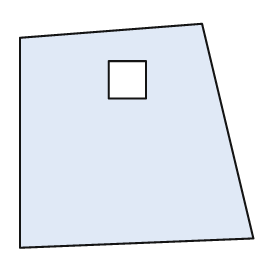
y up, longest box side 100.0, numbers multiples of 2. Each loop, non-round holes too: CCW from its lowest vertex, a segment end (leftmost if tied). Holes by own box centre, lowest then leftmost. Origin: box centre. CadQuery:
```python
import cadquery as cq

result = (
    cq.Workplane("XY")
    .moveTo(-50.0, -48.0)
    .lineTo(50.0, -44.0)
    .lineTo(28.0, 48.0)
    .lineTo(-50.0, 42.0)
    .close()
    .moveTo(-12.0, 16.0)
    .lineTo(4.0, 16.0)
    .lineTo(4.0, 32.0)
    .lineTo(-12.0, 32.0)
    .close()
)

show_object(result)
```